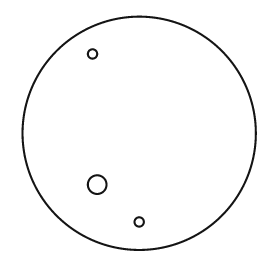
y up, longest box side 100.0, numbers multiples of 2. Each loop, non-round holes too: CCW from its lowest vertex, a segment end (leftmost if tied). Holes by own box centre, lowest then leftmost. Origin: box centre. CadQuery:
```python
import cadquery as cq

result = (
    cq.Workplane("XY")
    .moveTo(0.0, 0.0)
    .circle(50.0)
    .moveTo(0.0, -38.0)
    .circle(2.0)
    .moveTo(-18.0, -22.0)
    .circle(4.0)
    .moveTo(-20.0, 34.0)
    .circle(2.0)
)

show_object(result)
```